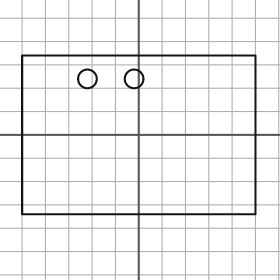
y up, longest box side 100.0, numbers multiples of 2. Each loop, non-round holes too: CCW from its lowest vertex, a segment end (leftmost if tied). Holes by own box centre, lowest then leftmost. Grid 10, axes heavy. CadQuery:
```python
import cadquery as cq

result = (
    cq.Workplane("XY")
    .moveTo(-50.0, -34.0)
    .lineTo(50.0, -34.0)
    .lineTo(50.0, 34.0)
    .lineTo(-50.0, 34.0)
    .close()
    .moveTo(-22.0, 24.0)
    .circle(4.0)
    .moveTo(-2.0, 24.0)
    .circle(4.0)
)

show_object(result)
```